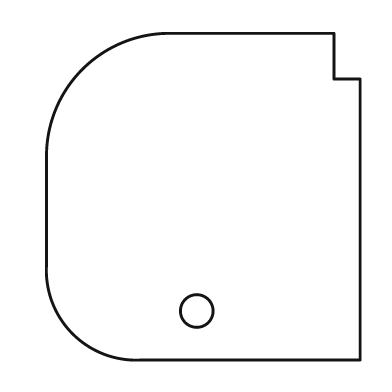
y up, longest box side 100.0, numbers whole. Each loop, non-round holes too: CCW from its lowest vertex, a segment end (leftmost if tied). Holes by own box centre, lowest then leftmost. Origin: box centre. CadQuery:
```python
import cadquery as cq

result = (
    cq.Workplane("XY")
    .moveTo(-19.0, -50.0)
    .lineTo(48.0, -50.0)
    .lineTo(48.0, 36.0)
    .lineTo(40.0, 36.0)
    .lineTo(40.0, 50.0)
    .lineTo(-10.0, 50.0)
    .threePointArc((-37.0, 39.0), (-48.0, 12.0))
    .lineTo(-48.0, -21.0)
    .threePointArc((-40.0, -42.0), (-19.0, -50.0))
    .close()
    .moveTo(-2.0, -35.0)
    .circle(5.0)
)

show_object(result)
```